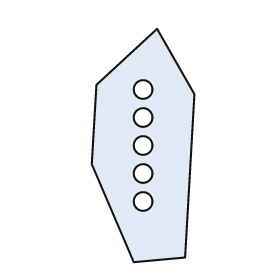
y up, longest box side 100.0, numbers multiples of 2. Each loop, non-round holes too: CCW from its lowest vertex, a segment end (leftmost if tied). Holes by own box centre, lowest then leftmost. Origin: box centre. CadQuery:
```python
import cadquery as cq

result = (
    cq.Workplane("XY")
    .moveTo(-4.0, -50.0)
    .lineTo(18.0, -48.0)
    .lineTo(22.0, 22.0)
    .lineTo(6.0, 50.0)
    .lineTo(-20.0, 26.0)
    .lineTo(-22.0, -8.0)
    .close()
    .moveTo(0.0, -24.0)
    .circle(4.0)
    .moveTo(0.0, -12.0)
    .circle(4.0)
    .moveTo(0.0, 0.0)
    .circle(4.0)
    .moveTo(0.0, 12.0)
    .circle(4.0)
    .moveTo(0.0, 24.0)
    .circle(4.0)
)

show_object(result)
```